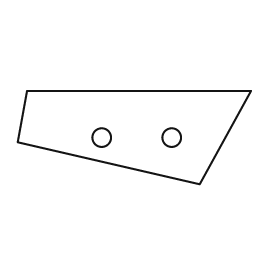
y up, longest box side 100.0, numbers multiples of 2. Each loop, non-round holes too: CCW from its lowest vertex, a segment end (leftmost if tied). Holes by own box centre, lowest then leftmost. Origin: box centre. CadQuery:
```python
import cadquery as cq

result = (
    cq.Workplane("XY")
    .moveTo(28.0, -20.0)
    .lineTo(50.0, 20.0)
    .lineTo(-46.0, 20.0)
    .lineTo(-50.0, -2.0)
    .close()
    .moveTo(-14.0, 0.0)
    .circle(4.0)
    .moveTo(16.0, 0.0)
    .circle(4.0)
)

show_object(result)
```